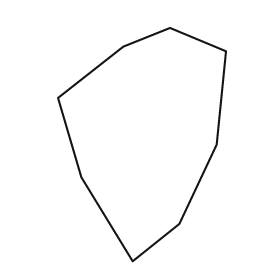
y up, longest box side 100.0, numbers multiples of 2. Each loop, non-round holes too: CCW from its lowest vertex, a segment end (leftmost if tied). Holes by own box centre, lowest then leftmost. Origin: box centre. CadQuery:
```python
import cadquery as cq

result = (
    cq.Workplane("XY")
    .moveTo(-4.0, -50.0)
    .lineTo(16.0, -34.0)
    .lineTo(32.0, 0.0)
    .lineTo(36.0, 40.0)
    .lineTo(12.0, 50.0)
    .lineTo(-8.0, 42.0)
    .lineTo(-36.0, 20.0)
    .lineTo(-26.0, -14.0)
    .close()
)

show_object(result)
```